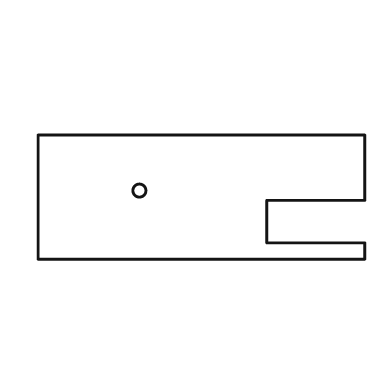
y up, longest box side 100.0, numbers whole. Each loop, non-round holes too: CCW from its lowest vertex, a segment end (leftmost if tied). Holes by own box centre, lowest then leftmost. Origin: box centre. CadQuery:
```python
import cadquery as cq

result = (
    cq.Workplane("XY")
    .moveTo(-50.0, -19.0)
    .lineTo(50.0, -19.0)
    .lineTo(50.0, -14.0)
    .lineTo(20.0, -14.0)
    .lineTo(20.0, -1.0)
    .lineTo(50.0, -1.0)
    .lineTo(50.0, 19.0)
    .lineTo(-50.0, 19.0)
    .close()
    .moveTo(-19.0, 2.0)
    .circle(2.0)
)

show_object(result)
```